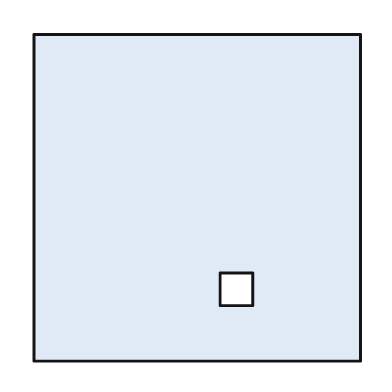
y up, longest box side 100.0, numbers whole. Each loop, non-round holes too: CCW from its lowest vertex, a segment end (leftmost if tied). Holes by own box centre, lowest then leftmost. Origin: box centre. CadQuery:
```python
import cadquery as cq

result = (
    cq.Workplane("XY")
    .moveTo(-50.0, -50.0)
    .lineTo(50.0, -50.0)
    .lineTo(50.0, 50.0)
    .lineTo(-50.0, 50.0)
    .close()
    .moveTo(7.0, -33.0)
    .lineTo(17.0, -33.0)
    .lineTo(17.0, -23.0)
    .lineTo(7.0, -23.0)
    .close()
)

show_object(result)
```